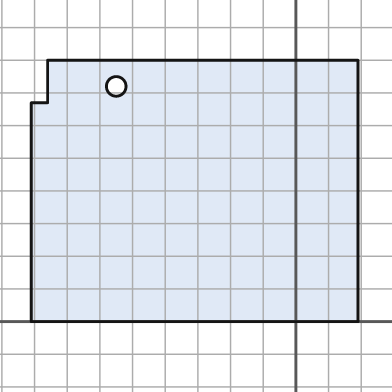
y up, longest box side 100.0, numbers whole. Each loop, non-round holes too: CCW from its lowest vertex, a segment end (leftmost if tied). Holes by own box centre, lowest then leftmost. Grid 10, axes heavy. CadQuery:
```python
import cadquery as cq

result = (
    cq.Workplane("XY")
    .moveTo(-81.0, 0.0)
    .lineTo(19.0, 0.0)
    .lineTo(19.0, 80.0)
    .lineTo(-76.0, 80.0)
    .lineTo(-76.0, 67.0)
    .lineTo(-81.0, 67.0)
    .close()
    .moveTo(-55.0, 72.0)
    .circle(3.0)
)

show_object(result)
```